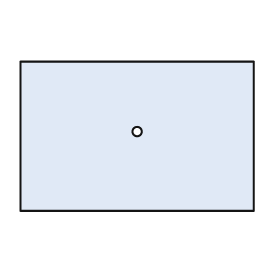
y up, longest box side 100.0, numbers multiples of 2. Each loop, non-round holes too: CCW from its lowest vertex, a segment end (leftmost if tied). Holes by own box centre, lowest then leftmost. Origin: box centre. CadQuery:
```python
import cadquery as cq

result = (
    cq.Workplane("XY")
    .moveTo(-50.0, -32.0)
    .lineTo(50.0, -32.0)
    .lineTo(50.0, 32.0)
    .lineTo(-50.0, 32.0)
    .close()
    .moveTo(0.0, 2.0)
    .circle(2.0)
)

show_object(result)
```